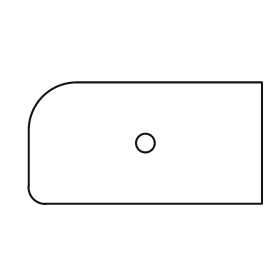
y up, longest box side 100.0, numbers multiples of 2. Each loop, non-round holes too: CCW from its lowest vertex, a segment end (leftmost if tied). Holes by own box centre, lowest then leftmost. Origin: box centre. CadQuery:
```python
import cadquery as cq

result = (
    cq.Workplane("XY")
    .moveTo(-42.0, -26.0)
    .lineTo(50.0, -26.0)
    .lineTo(50.0, 26.0)
    .lineTo(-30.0, 26.0)
    .threePointArc((-44.0, 20.0), (-50.0, 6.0))
    .lineTo(-50.0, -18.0)
    .threePointArc((-48.0, -24.0), (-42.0, -26.0))
    .close()
    .moveTo(0.0, 0.0)
    .circle(4.0)
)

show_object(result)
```